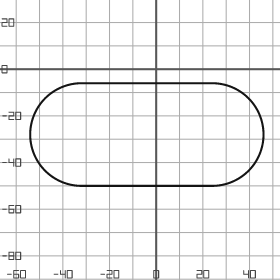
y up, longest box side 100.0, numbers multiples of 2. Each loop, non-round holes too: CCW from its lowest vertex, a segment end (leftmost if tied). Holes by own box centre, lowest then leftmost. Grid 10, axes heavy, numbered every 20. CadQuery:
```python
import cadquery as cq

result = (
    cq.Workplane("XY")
    .moveTo(-32.0, -50.0)
    .lineTo(24.0, -50.0)
    .threePointArc((46.0, -28.0), (24.0, -6.0))
    .lineTo(-32.0, -6.0)
    .threePointArc((-54.0, -28.0), (-32.0, -50.0))
    .close()
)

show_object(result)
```